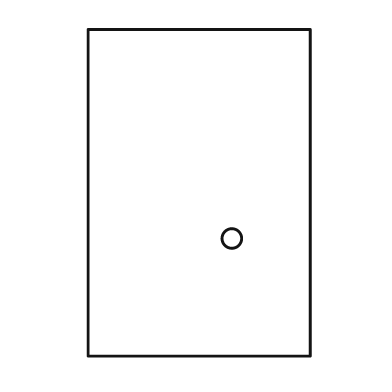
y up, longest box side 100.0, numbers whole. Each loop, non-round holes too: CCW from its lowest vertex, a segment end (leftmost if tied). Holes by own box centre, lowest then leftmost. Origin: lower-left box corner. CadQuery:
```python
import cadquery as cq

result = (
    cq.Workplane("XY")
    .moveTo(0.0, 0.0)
    .lineTo(68.0, 0.0)
    .lineTo(68.0, 100.0)
    .lineTo(0.0, 100.0)
    .close()
    .moveTo(44.0, 36.0)
    .circle(3.0)
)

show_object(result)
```